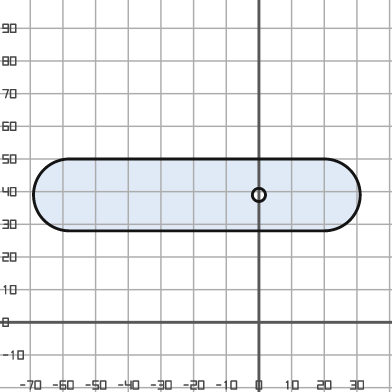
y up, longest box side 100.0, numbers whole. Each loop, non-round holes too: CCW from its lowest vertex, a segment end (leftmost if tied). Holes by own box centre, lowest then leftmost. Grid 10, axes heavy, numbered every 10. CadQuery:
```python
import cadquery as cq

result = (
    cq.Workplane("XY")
    .moveTo(-58.0, 28.0)
    .lineTo(20.0, 28.0)
    .threePointArc((31.0, 39.0), (20.0, 50.0))
    .lineTo(-58.0, 50.0)
    .threePointArc((-69.0, 39.0), (-58.0, 28.0))
    .close()
    .moveTo(0.0, 39.0)
    .circle(2.0)
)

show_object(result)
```